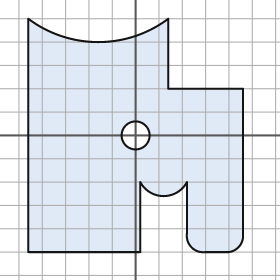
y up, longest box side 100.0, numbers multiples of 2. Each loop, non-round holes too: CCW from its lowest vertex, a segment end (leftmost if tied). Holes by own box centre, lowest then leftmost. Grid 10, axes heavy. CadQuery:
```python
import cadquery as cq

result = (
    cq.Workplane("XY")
    .moveTo(-46.0, -50.0)
    .lineTo(2.0, -50.0)
    .lineTo(2.0, -20.0)
    .threePointArc((12.0, -26.0), (22.0, -20.0))
    .lineTo(22.0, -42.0)
    .threePointArc((24.0, -48.0), (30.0, -50.0))
    .lineTo(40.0, -50.0)
    .threePointArc((44.0, -48.0), (46.0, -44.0))
    .lineTo(46.0, 20.0)
    .lineTo(14.0, 20.0)
    .lineTo(14.0, 50.0)
    .threePointArc((-16.0, 40.0), (-46.0, 50.0))
    .close()
    .moveTo(0.0, 0.0)
    .circle(6.0)
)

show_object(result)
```